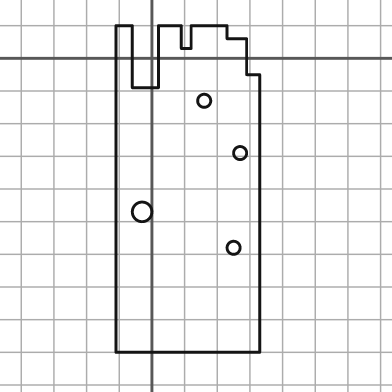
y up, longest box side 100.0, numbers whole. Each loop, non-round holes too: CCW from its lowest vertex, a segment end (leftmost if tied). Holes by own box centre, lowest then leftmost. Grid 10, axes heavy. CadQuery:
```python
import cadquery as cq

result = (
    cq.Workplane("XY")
    .moveTo(-11.0, -90.0)
    .lineTo(33.0, -90.0)
    .lineTo(33.0, -5.0)
    .lineTo(29.0, -5.0)
    .lineTo(29.0, 6.0)
    .lineTo(23.0, 6.0)
    .lineTo(23.0, 10.0)
    .lineTo(12.0, 10.0)
    .lineTo(12.0, 3.0)
    .lineTo(9.0, 3.0)
    .lineTo(9.0, 10.0)
    .lineTo(2.0, 10.0)
    .lineTo(2.0, -9.0)
    .lineTo(-6.0, -9.0)
    .lineTo(-6.0, 10.0)
    .lineTo(-11.0, 10.0)
    .close()
    .moveTo(25.0, -58.0)
    .circle(2.0)
    .moveTo(-3.0, -47.0)
    .circle(3.0)
    .moveTo(27.0, -29.0)
    .circle(2.0)
    .moveTo(16.0, -13.0)
    .circle(2.0)
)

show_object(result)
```